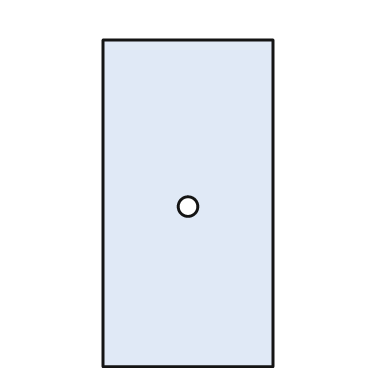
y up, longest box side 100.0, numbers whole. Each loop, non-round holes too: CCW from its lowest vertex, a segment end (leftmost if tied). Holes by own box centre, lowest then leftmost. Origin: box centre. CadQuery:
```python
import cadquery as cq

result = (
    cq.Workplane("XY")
    .moveTo(-26.0, -50.0)
    .lineTo(26.0, -50.0)
    .lineTo(26.0, 50.0)
    .lineTo(-26.0, 50.0)
    .close()
    .moveTo(0.0, -1.0)
    .circle(3.0)
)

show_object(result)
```